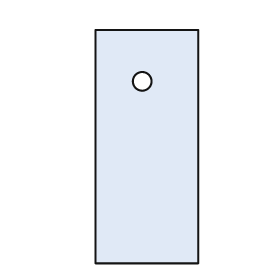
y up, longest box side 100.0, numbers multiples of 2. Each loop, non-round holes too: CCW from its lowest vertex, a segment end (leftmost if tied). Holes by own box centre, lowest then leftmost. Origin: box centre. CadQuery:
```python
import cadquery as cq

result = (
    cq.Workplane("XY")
    .moveTo(-22.0, -50.0)
    .lineTo(22.0, -50.0)
    .lineTo(22.0, 50.0)
    .lineTo(-22.0, 50.0)
    .close()
    .moveTo(-2.0, 28.0)
    .circle(4.0)
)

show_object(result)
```